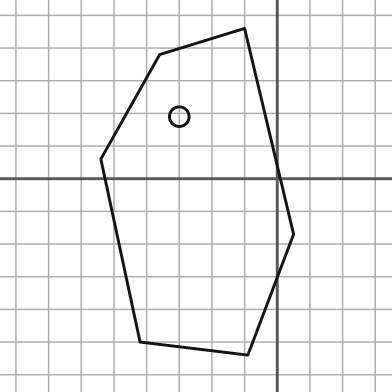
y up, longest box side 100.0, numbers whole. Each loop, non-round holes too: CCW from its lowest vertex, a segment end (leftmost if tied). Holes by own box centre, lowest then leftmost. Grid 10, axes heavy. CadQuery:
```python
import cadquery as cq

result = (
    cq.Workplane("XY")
    .moveTo(-9.0, -54.0)
    .lineTo(5.0, -17.0)
    .lineTo(-10.0, 46.0)
    .lineTo(-36.0, 38.0)
    .lineTo(-54.0, 6.0)
    .lineTo(-42.0, -50.0)
    .close()
    .moveTo(-30.0, 19.0)
    .circle(3.0)
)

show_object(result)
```